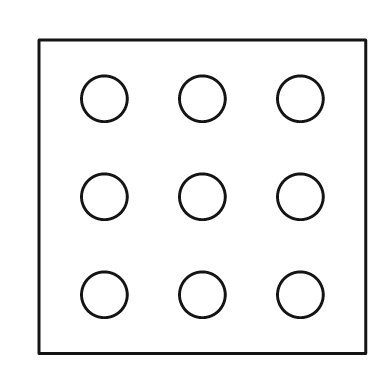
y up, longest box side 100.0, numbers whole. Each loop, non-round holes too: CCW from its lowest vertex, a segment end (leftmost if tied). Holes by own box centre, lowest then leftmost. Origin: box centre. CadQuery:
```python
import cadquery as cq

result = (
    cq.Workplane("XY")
    .moveTo(-50.0, -48.0)
    .lineTo(50.0, -48.0)
    .lineTo(50.0, 48.0)
    .lineTo(-50.0, 48.0)
    .close()
    .moveTo(-30.0, -30.0)
    .circle(7.0)
    .moveTo(0.0, -30.0)
    .circle(7.0)
    .moveTo(30.0, -30.0)
    .circle(7.0)
    .moveTo(-30.0, 0.0)
    .circle(7.0)
    .moveTo(0.0, 0.0)
    .circle(7.0)
    .moveTo(30.0, 0.0)
    .circle(7.0)
    .moveTo(-30.0, 30.0)
    .circle(7.0)
    .moveTo(0.0, 30.0)
    .circle(7.0)
    .moveTo(30.0, 30.0)
    .circle(7.0)
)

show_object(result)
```